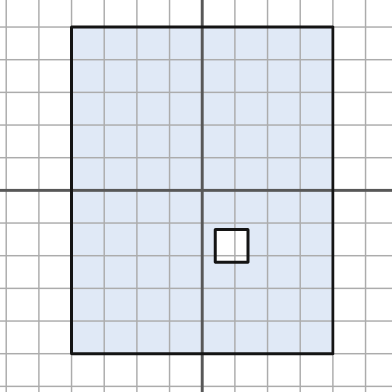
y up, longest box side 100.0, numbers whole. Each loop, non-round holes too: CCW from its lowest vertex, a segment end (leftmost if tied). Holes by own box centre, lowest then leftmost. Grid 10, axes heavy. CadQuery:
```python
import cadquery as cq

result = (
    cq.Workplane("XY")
    .moveTo(-40.0, -50.0)
    .lineTo(40.0, -50.0)
    .lineTo(40.0, 50.0)
    .lineTo(-40.0, 50.0)
    .close()
    .moveTo(4.0, -22.0)
    .lineTo(14.0, -22.0)
    .lineTo(14.0, -12.0)
    .lineTo(4.0, -12.0)
    .close()
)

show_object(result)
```